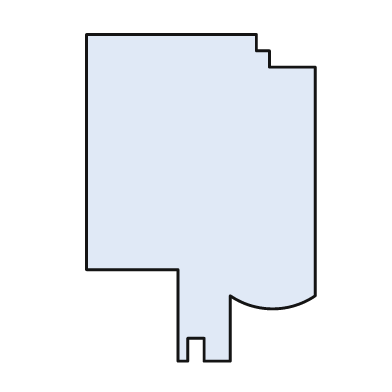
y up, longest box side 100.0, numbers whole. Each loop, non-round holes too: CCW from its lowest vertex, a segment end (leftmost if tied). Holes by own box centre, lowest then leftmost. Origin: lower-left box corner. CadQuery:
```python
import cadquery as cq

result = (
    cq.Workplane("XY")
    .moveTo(28.0, 0.0)
    .lineTo(31.0, 0.0)
    .lineTo(31.0, 7.0)
    .lineTo(36.0, 7.0)
    .lineTo(36.0, 0.0)
    .lineTo(44.0, 0.0)
    .lineTo(44.0, 20.0)
    .threePointArc((57.0, 16.0), (70.0, 20.0))
    .lineTo(70.0, 90.0)
    .lineTo(56.0, 90.0)
    .lineTo(56.0, 95.0)
    .lineTo(52.0, 95.0)
    .lineTo(52.0, 100.0)
    .lineTo(0.0, 100.0)
    .lineTo(0.0, 28.0)
    .lineTo(28.0, 28.0)
    .close()
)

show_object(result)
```